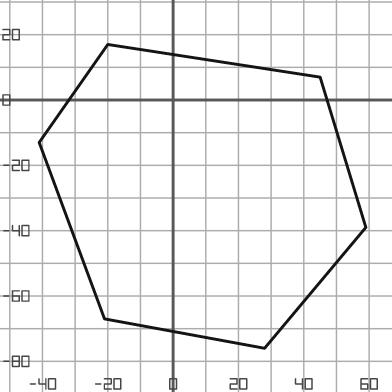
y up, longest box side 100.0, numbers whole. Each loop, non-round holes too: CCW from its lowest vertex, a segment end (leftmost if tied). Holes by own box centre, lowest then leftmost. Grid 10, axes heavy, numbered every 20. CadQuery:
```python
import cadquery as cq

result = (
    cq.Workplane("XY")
    .moveTo(28.0, -76.0)
    .lineTo(59.0, -39.0)
    .lineTo(45.0, 7.0)
    .lineTo(-20.0, 17.0)
    .lineTo(-41.0, -13.0)
    .lineTo(-21.0, -67.0)
    .close()
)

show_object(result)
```